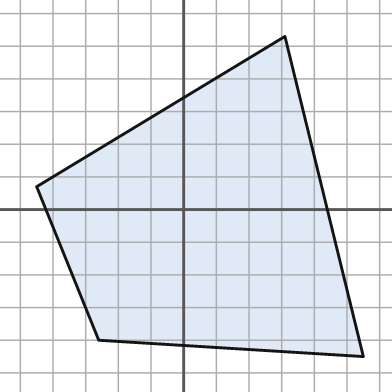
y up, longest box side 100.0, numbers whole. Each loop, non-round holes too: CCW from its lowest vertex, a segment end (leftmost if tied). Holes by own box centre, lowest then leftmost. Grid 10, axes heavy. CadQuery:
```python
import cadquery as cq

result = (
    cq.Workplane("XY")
    .moveTo(55.0, -45.0)
    .lineTo(31.0, 53.0)
    .lineTo(-45.0, 7.0)
    .lineTo(-26.0, -40.0)
    .close()
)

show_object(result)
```